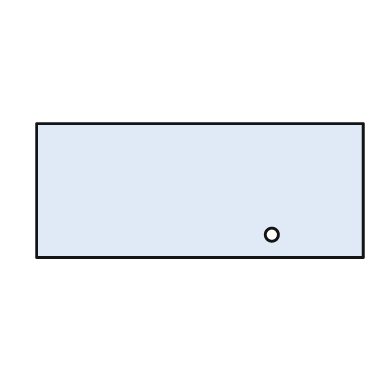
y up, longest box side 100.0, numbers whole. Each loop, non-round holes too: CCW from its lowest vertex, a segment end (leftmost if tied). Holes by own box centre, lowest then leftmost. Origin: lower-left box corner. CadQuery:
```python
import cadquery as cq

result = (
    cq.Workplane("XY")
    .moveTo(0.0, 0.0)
    .lineTo(100.0, 0.0)
    .lineTo(100.0, 41.0)
    .lineTo(0.0, 41.0)
    .close()
    .moveTo(72.0, 7.0)
    .circle(2.0)
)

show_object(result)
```